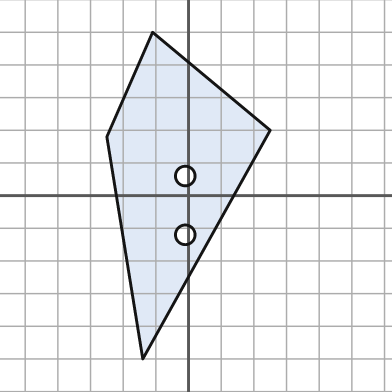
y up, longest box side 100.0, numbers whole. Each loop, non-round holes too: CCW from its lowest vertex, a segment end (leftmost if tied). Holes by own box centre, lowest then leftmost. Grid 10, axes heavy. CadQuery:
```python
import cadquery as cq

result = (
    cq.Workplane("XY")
    .moveTo(-14.0, -50.0)
    .lineTo(25.0, 20.0)
    .lineTo(-11.0, 50.0)
    .lineTo(-25.0, 18.0)
    .close()
    .moveTo(-1.0, -12.0)
    .circle(3.0)
    .moveTo(-1.0, 6.0)
    .circle(3.0)
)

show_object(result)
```